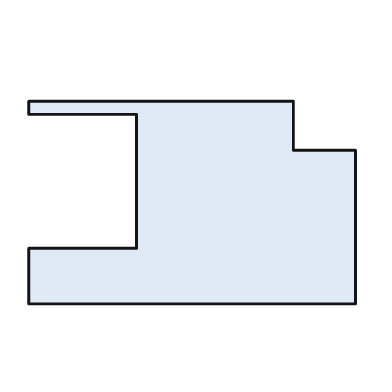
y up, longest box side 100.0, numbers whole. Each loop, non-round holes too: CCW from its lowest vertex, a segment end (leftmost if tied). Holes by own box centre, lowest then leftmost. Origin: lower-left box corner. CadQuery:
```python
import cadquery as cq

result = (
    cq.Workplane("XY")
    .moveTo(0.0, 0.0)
    .lineTo(100.0, 0.0)
    .lineTo(100.0, 47.0)
    .lineTo(81.0, 47.0)
    .lineTo(81.0, 62.0)
    .lineTo(0.0, 62.0)
    .lineTo(0.0, 58.0)
    .lineTo(33.0, 58.0)
    .lineTo(33.0, 17.0)
    .lineTo(0.0, 17.0)
    .close()
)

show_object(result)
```